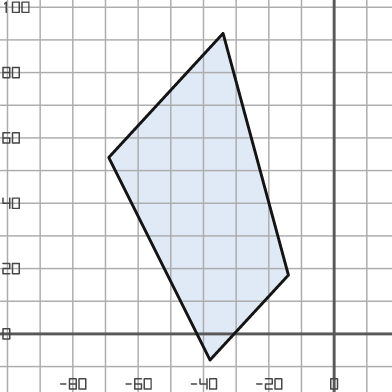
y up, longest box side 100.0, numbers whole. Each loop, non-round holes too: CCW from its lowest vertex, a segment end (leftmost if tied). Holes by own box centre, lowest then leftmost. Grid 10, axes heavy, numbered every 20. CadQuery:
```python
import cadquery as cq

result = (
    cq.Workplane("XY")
    .moveTo(-38.0, -8.0)
    .lineTo(-14.0, 18.0)
    .lineTo(-34.0, 92.0)
    .lineTo(-69.0, 54.0)
    .close()
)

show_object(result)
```